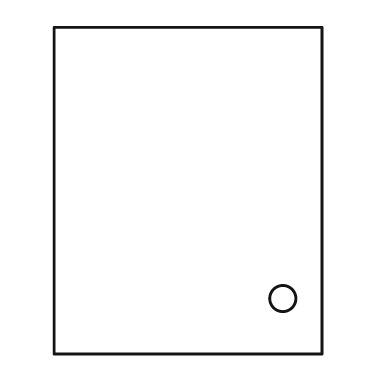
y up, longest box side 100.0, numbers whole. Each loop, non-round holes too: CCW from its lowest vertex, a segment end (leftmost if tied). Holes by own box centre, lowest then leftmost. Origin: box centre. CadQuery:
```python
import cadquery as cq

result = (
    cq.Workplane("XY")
    .moveTo(-41.0, -50.0)
    .lineTo(41.0, -50.0)
    .lineTo(41.0, 50.0)
    .lineTo(-41.0, 50.0)
    .close()
    .moveTo(29.0, -33.0)
    .circle(4.0)
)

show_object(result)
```